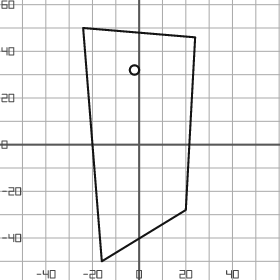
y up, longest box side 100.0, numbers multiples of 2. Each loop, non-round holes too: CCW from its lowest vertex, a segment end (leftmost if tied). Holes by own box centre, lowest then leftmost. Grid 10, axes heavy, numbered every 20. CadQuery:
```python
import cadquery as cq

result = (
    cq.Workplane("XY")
    .moveTo(-16.0, -50.0)
    .lineTo(20.0, -28.0)
    .lineTo(24.0, 46.0)
    .lineTo(-24.0, 50.0)
    .close()
    .moveTo(-2.0, 32.0)
    .circle(2.0)
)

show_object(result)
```